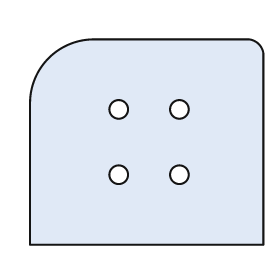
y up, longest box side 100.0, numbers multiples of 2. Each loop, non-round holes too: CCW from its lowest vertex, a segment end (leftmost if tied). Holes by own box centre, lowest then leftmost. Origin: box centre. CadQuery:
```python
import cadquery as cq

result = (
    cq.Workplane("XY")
    .moveTo(-50.0, -44.0)
    .lineTo(50.0, -44.0)
    .lineTo(50.0, 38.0)
    .threePointArc((48.0, 42.0), (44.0, 44.0))
    .lineTo(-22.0, 44.0)
    .threePointArc((-42.0, 36.0), (-50.0, 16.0))
    .close()
    .moveTo(-12.0, -14.0)
    .circle(4.0)
    .moveTo(14.0, -14.0)
    .circle(4.0)
    .moveTo(-12.0, 14.0)
    .circle(4.0)
    .moveTo(14.0, 14.0)
    .circle(4.0)
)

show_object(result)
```